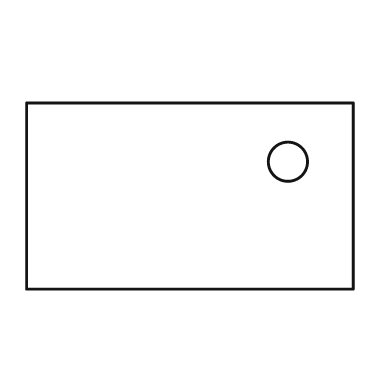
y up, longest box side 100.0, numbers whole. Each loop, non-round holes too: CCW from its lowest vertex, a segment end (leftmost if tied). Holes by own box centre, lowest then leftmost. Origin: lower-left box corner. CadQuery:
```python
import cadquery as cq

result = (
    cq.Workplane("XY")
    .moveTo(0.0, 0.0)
    .lineTo(100.0, 0.0)
    .lineTo(100.0, 57.0)
    .lineTo(0.0, 57.0)
    .close()
    .moveTo(80.0, 39.0)
    .circle(6.0)
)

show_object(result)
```